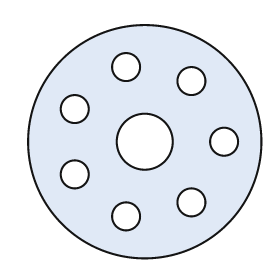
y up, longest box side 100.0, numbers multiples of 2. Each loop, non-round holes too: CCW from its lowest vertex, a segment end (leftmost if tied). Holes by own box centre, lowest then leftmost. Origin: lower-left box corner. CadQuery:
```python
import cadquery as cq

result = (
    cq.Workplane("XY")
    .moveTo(50.0, 50.0)
    .circle(50.0)
    .moveTo(42.0, 18.0)
    .circle(6.0)
    .moveTo(70.0, 24.0)
    .circle(6.0)
    .moveTo(20.0, 36.0)
    .circle(6.0)
    .moveTo(50.0, 50.0)
    .circle(12.0)
    .moveTo(84.0, 50.0)
    .circle(6.0)
    .moveTo(20.0, 64.0)
    .circle(6.0)
    .moveTo(70.0, 76.0)
    .circle(6.0)
    .moveTo(42.0, 82.0)
    .circle(6.0)
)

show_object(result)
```